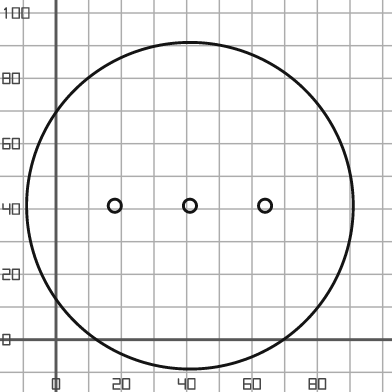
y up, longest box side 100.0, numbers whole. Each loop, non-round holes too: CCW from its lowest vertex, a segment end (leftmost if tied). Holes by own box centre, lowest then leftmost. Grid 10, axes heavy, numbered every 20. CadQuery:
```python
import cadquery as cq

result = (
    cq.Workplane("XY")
    .moveTo(41.0, 41.0)
    .circle(50.0)
    .moveTo(18.0, 41.0)
    .circle(2.0)
    .moveTo(41.0, 41.0)
    .circle(2.0)
    .moveTo(64.0, 41.0)
    .circle(2.0)
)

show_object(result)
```